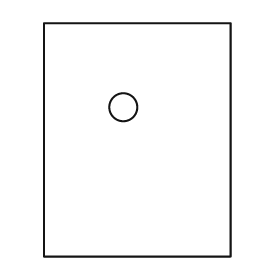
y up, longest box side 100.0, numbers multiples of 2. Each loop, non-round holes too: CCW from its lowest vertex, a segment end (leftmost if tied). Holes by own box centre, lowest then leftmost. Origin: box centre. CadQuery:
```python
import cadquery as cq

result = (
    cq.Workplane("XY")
    .moveTo(-40.0, -50.0)
    .lineTo(40.0, -50.0)
    .lineTo(40.0, 50.0)
    .lineTo(-40.0, 50.0)
    .close()
    .moveTo(-6.0, 14.0)
    .circle(6.0)
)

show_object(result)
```